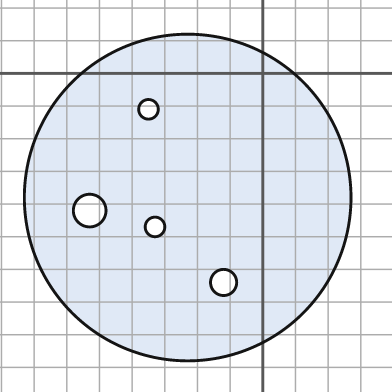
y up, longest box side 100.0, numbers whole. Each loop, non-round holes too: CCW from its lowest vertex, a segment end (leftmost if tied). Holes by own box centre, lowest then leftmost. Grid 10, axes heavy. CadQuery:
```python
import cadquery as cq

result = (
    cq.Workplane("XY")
    .moveTo(-23.0, -38.0)
    .circle(50.0)
    .moveTo(-12.0, -64.0)
    .circle(4.0)
    .moveTo(-33.0, -47.0)
    .circle(3.0)
    .moveTo(-53.0, -42.0)
    .circle(5.0)
    .moveTo(-35.0, -11.0)
    .circle(3.0)
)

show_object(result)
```